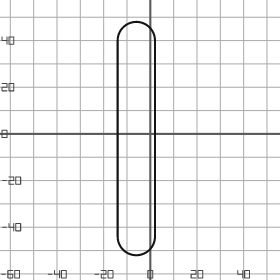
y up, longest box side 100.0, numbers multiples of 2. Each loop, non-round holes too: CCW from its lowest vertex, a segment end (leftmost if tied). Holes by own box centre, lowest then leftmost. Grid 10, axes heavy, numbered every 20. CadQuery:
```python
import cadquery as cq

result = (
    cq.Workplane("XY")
    .moveTo(-14.0, -44.0)
    .threePointArc((-6.0, -52.0), (2.0, -44.0))
    .lineTo(2.0, 40.0)
    .threePointArc((-6.0, 48.0), (-14.0, 40.0))
    .close()
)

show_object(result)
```